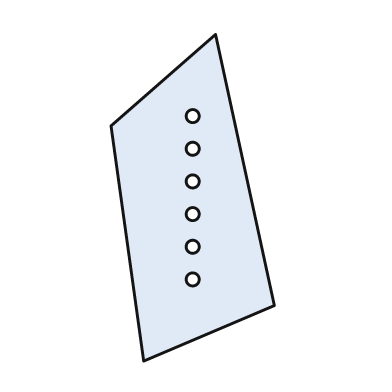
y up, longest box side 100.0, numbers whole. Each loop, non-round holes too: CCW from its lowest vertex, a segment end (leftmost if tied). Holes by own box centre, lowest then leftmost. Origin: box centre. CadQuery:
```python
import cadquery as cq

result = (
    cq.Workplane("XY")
    .moveTo(-15.0, -50.0)
    .lineTo(25.0, -33.0)
    .lineTo(7.0, 50.0)
    .lineTo(-25.0, 22.0)
    .close()
    .moveTo(0.0, -25.0)
    .circle(2.0)
    .moveTo(0.0, -15.0)
    .circle(2.0)
    .moveTo(0.0, -5.0)
    .circle(2.0)
    .moveTo(0.0, 5.0)
    .circle(2.0)
    .moveTo(0.0, 15.0)
    .circle(2.0)
    .moveTo(0.0, 25.0)
    .circle(2.0)
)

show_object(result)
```